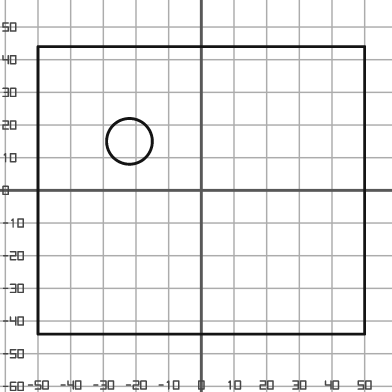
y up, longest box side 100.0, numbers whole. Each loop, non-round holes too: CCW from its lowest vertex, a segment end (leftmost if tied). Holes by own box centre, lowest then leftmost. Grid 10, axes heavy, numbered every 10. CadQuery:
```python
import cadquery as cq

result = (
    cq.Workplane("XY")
    .moveTo(-50.0, -44.0)
    .lineTo(50.0, -44.0)
    .lineTo(50.0, 44.0)
    .lineTo(-50.0, 44.0)
    .close()
    .moveTo(-22.0, 15.0)
    .circle(7.0)
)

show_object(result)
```